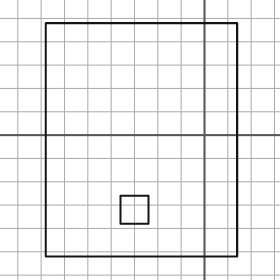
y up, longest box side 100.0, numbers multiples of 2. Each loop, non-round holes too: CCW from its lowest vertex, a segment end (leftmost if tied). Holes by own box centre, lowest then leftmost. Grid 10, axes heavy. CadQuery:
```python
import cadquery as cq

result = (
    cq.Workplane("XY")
    .moveTo(-68.0, -52.0)
    .lineTo(14.0, -52.0)
    .lineTo(14.0, 48.0)
    .lineTo(-68.0, 48.0)
    .close()
    .moveTo(-36.0, -38.0)
    .lineTo(-24.0, -38.0)
    .lineTo(-24.0, -26.0)
    .lineTo(-36.0, -26.0)
    .close()
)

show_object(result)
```